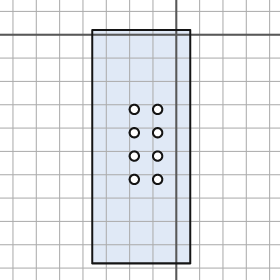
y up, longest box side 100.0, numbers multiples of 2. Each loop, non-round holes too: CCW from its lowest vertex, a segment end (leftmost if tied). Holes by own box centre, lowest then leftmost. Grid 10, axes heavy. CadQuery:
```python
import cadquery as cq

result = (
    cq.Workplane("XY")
    .moveTo(-36.0, -98.0)
    .lineTo(6.0, -98.0)
    .lineTo(6.0, 2.0)
    .lineTo(-36.0, 2.0)
    .close()
    .moveTo(-18.0, -62.0)
    .circle(2.0)
    .moveTo(-8.0, -62.0)
    .circle(2.0)
    .moveTo(-18.0, -52.0)
    .circle(2.0)
    .moveTo(-8.0, -52.0)
    .circle(2.0)
    .moveTo(-18.0, -42.0)
    .circle(2.0)
    .moveTo(-8.0, -42.0)
    .circle(2.0)
    .moveTo(-18.0, -32.0)
    .circle(2.0)
    .moveTo(-8.0, -32.0)
    .circle(2.0)
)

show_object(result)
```